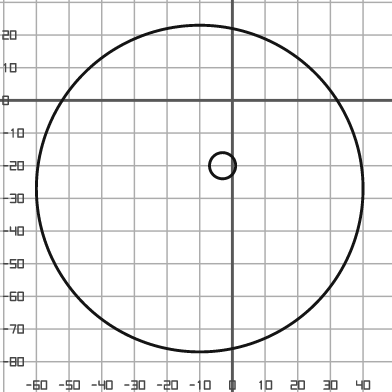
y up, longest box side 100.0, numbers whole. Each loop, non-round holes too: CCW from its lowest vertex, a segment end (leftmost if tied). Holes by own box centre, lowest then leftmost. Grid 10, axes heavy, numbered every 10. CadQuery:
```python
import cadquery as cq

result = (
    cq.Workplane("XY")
    .moveTo(-10.0, -27.0)
    .circle(50.0)
    .moveTo(-3.0, -20.0)
    .circle(4.0)
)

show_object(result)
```